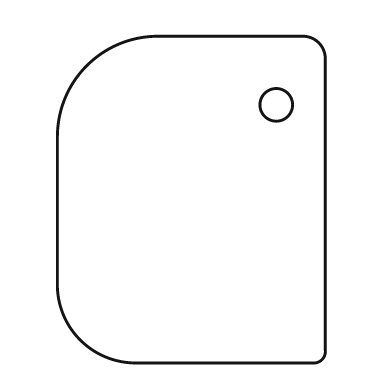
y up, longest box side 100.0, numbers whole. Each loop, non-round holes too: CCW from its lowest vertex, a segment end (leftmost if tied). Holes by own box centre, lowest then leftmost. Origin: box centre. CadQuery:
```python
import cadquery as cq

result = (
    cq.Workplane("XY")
    .moveTo(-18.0, -50.0)
    .lineTo(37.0, -50.0)
    .threePointArc((40.0, -49.0), (41.0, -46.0))
    .lineTo(41.0, 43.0)
    .threePointArc((39.0, 48.0), (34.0, 50.0))
    .lineTo(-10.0, 50.0)
    .threePointArc((-32.0, 41.0), (-41.0, 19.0))
    .lineTo(-41.0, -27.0)
    .threePointArc((-34.0, -43.0), (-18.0, -50.0))
    .close()
    .moveTo(26.0, 29.0)
    .circle(5.0)
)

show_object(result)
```